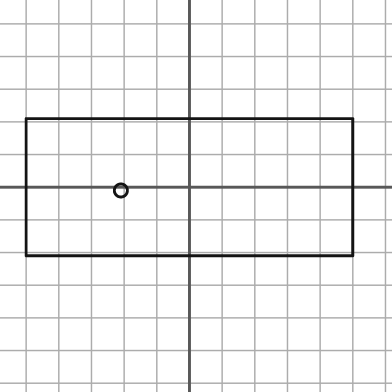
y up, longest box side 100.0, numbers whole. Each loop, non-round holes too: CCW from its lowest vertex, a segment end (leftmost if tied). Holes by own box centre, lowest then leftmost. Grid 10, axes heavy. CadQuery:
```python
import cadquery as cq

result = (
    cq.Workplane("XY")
    .moveTo(-50.0, -21.0)
    .lineTo(50.0, -21.0)
    .lineTo(50.0, 21.0)
    .lineTo(-50.0, 21.0)
    .close()
    .moveTo(-21.0, -1.0)
    .circle(2.0)
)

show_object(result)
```